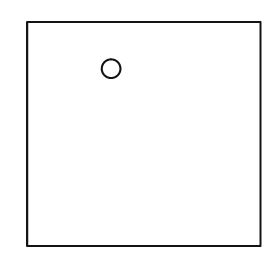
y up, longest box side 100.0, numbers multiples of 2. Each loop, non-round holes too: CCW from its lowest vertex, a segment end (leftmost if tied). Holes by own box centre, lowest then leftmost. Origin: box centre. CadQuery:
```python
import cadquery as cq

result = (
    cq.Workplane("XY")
    .moveTo(-50.0, -48.0)
    .lineTo(50.0, -48.0)
    .lineTo(50.0, 48.0)
    .lineTo(-50.0, 48.0)
    .close()
    .moveTo(-14.0, 28.0)
    .circle(4.0)
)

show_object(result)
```